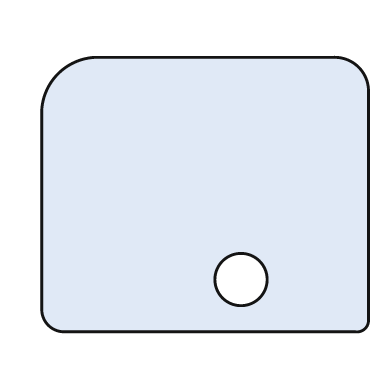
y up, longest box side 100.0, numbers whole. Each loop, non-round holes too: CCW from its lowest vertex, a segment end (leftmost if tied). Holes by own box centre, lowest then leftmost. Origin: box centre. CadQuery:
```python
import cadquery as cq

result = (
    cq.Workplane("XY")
    .moveTo(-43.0, -42.0)
    .lineTo(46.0, -42.0)
    .threePointArc((49.0, -41.0), (50.0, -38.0))
    .lineTo(50.0, 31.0)
    .threePointArc((47.0, 39.0), (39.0, 42.0))
    .lineTo(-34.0, 42.0)
    .threePointArc((-45.0, 37.0), (-50.0, 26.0))
    .lineTo(-50.0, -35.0)
    .threePointArc((-48.0, -40.0), (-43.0, -42.0))
    .close()
    .moveTo(11.0, -26.0)
    .circle(8.0)
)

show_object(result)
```